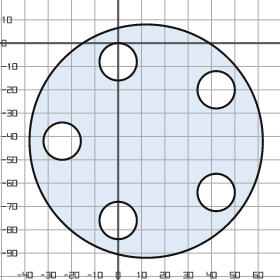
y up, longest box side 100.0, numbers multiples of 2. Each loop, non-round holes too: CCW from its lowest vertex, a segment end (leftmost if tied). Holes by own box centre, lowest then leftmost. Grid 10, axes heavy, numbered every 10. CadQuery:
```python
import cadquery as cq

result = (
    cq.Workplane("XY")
    .moveTo(12.0, -42.0)
    .circle(50.0)
    .moveTo(0.0, -76.0)
    .circle(8.0)
    .moveTo(42.0, -64.0)
    .circle(8.0)
    .moveTo(-24.0, -42.0)
    .circle(8.0)
    .moveTo(42.0, -20.0)
    .circle(8.0)
    .moveTo(0.0, -8.0)
    .circle(8.0)
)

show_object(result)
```